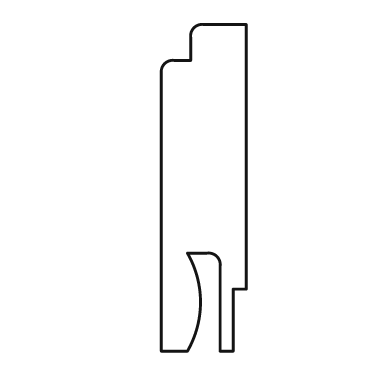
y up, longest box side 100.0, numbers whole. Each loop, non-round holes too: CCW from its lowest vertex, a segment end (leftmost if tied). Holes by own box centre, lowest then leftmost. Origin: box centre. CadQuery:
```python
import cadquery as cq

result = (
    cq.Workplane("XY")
    .moveTo(-13.0, -50.0)
    .lineTo(-5.0, -50.0)
    .threePointArc((-1.0, -35.0), (-5.0, -20.0))
    .lineTo(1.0, -20.0)
    .threePointArc((4.0, -21.0), (5.0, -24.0))
    .lineTo(5.0, -50.0)
    .lineTo(9.0, -50.0)
    .lineTo(9.0, -31.0)
    .lineTo(13.0, -31.0)
    .lineTo(13.0, 50.0)
    .lineTo(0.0, 50.0)
    .threePointArc((-3.0, 49.0), (-4.0, 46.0))
    .lineTo(-4.0, 39.0)
    .lineTo(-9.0, 39.0)
    .threePointArc((-12.0, 38.0), (-13.0, 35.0))
    .close()
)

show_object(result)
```